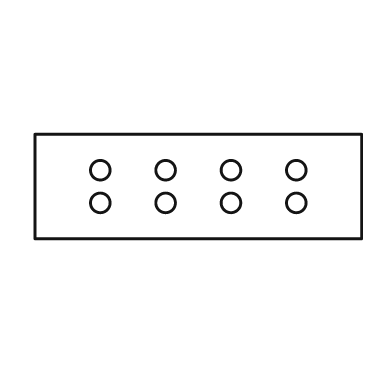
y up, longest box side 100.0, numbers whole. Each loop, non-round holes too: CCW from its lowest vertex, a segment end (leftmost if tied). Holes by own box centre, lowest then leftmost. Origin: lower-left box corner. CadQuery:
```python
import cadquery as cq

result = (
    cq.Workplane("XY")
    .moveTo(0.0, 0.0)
    .lineTo(100.0, 0.0)
    .lineTo(100.0, 32.0)
    .lineTo(0.0, 32.0)
    .close()
    .moveTo(20.0, 11.0)
    .circle(3.0)
    .moveTo(40.0, 11.0)
    .circle(3.0)
    .moveTo(60.0, 11.0)
    .circle(3.0)
    .moveTo(80.0, 11.0)
    .circle(3.0)
    .moveTo(20.0, 21.0)
    .circle(3.0)
    .moveTo(40.0, 21.0)
    .circle(3.0)
    .moveTo(60.0, 21.0)
    .circle(3.0)
    .moveTo(80.0, 21.0)
    .circle(3.0)
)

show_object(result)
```